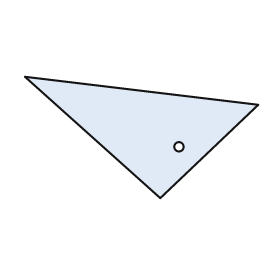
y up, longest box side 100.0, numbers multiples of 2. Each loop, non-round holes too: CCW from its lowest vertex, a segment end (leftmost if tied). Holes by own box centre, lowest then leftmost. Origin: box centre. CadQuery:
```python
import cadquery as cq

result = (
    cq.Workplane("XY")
    .moveTo(8.0, -26.0)
    .lineTo(50.0, 14.0)
    .lineTo(-50.0, 26.0)
    .close()
    .moveTo(16.0, -4.0)
    .circle(2.0)
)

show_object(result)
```